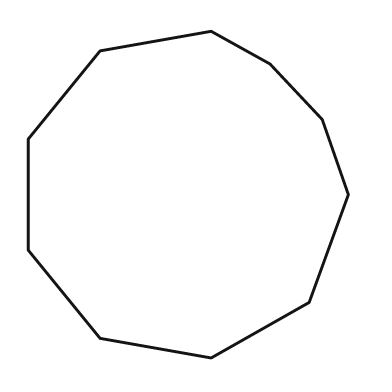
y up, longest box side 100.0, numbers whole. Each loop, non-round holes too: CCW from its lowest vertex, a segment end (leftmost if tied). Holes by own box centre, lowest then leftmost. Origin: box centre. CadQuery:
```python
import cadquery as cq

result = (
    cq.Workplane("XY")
    .moveTo(7.0, -50.0)
    .lineTo(37.0, -33.0)
    .lineTo(49.0, 0.0)
    .lineTo(41.0, 23.0)
    .lineTo(25.0, 40.0)
    .lineTo(7.0, 50.0)
    .lineTo(-27.0, 44.0)
    .lineTo(-49.0, 17.0)
    .lineTo(-49.0, -17.0)
    .lineTo(-27.0, -44.0)
    .close()
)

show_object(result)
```